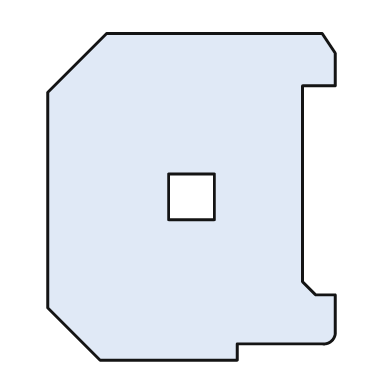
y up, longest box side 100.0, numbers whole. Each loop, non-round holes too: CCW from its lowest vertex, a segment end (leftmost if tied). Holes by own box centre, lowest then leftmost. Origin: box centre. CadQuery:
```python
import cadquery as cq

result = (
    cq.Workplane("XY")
    .moveTo(-28.0, -50.0)
    .lineTo(14.0, -50.0)
    .lineTo(14.0, -45.0)
    .lineTo(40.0, -45.0)
    .threePointArc((43.0, -44.0), (44.0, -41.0))
    .lineTo(44.0, -30.0)
    .lineTo(38.0, -30.0)
    .lineTo(34.0, -26.0)
    .lineTo(34.0, 34.0)
    .lineTo(44.0, 34.0)
    .lineTo(44.0, 44.0)
    .lineTo(40.0, 50.0)
    .lineTo(-26.0, 50.0)
    .lineTo(-44.0, 32.0)
    .lineTo(-44.0, -34.0)
    .close()
    .moveTo(-7.0, -7.0)
    .lineTo(7.0, -7.0)
    .lineTo(7.0, 7.0)
    .lineTo(-7.0, 7.0)
    .close()
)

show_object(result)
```